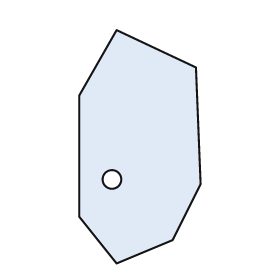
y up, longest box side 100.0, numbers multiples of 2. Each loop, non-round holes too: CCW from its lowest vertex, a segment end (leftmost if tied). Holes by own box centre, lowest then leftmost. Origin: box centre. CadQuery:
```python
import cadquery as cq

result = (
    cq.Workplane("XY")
    .moveTo(-10.0, -50.0)
    .lineTo(14.0, -40.0)
    .lineTo(26.0, -16.0)
    .lineTo(24.0, 34.0)
    .lineTo(-10.0, 50.0)
    .lineTo(-26.0, 22.0)
    .lineTo(-26.0, -30.0)
    .close()
    .moveTo(-12.0, -14.0)
    .circle(4.0)
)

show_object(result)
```